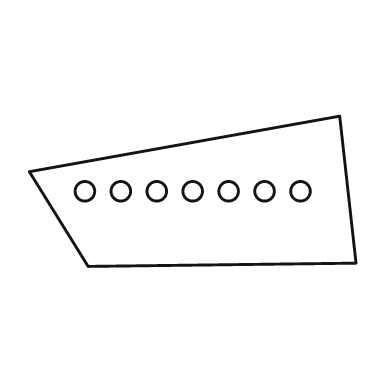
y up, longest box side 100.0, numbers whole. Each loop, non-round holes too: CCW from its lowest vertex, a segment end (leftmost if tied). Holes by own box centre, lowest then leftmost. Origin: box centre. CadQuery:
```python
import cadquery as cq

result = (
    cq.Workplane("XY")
    .moveTo(-32.0, -23.0)
    .lineTo(50.0, -22.0)
    .lineTo(45.0, 23.0)
    .lineTo(-50.0, 6.0)
    .close()
    .moveTo(-33.0, 0.0)
    .circle(3.0)
    .moveTo(-22.0, 0.0)
    .circle(3.0)
    .moveTo(-11.0, 0.0)
    .circle(3.0)
    .moveTo(0.0, 0.0)
    .circle(3.0)
    .moveTo(11.0, 0.0)
    .circle(3.0)
    .moveTo(22.0, 0.0)
    .circle(3.0)
    .moveTo(33.0, 0.0)
    .circle(3.0)
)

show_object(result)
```